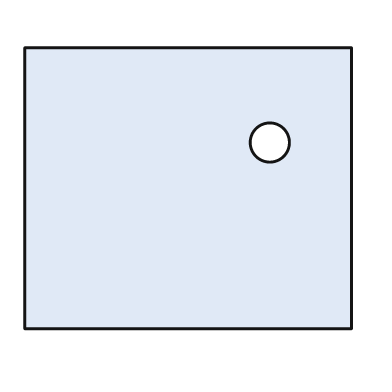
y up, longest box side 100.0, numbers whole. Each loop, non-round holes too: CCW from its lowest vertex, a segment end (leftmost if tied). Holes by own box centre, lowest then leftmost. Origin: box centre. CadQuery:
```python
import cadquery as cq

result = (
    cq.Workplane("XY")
    .moveTo(-50.0, -43.0)
    .lineTo(50.0, -43.0)
    .lineTo(50.0, 43.0)
    .lineTo(-50.0, 43.0)
    .close()
    .moveTo(25.0, 14.0)
    .circle(6.0)
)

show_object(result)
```